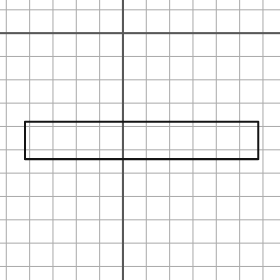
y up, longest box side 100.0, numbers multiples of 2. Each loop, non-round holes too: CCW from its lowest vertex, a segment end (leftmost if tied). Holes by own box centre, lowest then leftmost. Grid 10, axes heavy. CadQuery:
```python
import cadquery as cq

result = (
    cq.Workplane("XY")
    .moveTo(-42.0, -54.0)
    .lineTo(58.0, -54.0)
    .lineTo(58.0, -38.0)
    .lineTo(-42.0, -38.0)
    .close()
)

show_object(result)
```